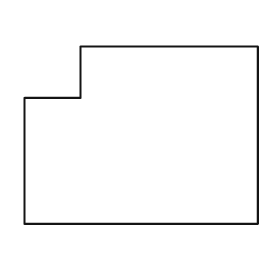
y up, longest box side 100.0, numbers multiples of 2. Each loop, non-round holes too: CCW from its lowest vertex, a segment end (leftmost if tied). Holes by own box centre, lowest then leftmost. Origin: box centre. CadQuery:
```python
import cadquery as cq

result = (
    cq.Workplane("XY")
    .moveTo(-50.0, -38.0)
    .lineTo(50.0, -38.0)
    .lineTo(50.0, 38.0)
    .lineTo(-26.0, 38.0)
    .lineTo(-26.0, 16.0)
    .lineTo(-50.0, 16.0)
    .close()
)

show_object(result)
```